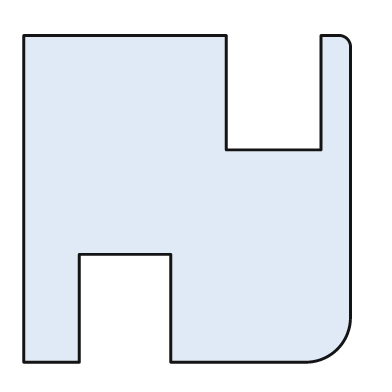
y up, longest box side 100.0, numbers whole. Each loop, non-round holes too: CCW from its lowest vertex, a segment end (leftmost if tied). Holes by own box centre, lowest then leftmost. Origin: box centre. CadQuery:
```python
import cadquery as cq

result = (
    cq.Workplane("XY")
    .moveTo(-50.0, -50.0)
    .lineTo(-33.0, -50.0)
    .lineTo(-33.0, -17.0)
    .lineTo(-5.0, -17.0)
    .lineTo(-5.0, -50.0)
    .lineTo(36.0, -50.0)
    .threePointArc((46.0, -46.0), (50.0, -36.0))
    .lineTo(50.0, 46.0)
    .threePointArc((49.0, 49.0), (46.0, 50.0))
    .lineTo(41.0, 50.0)
    .lineTo(41.0, 15.0)
    .lineTo(12.0, 15.0)
    .lineTo(12.0, 50.0)
    .lineTo(-50.0, 50.0)
    .close()
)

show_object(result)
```